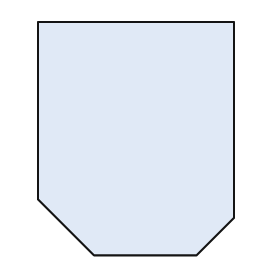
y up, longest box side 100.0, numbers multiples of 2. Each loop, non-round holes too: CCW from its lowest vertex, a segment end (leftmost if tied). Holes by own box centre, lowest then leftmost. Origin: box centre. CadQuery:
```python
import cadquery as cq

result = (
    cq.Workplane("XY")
    .moveTo(-18.0, -50.0)
    .lineTo(26.0, -50.0)
    .lineTo(42.0, -34.0)
    .lineTo(42.0, 50.0)
    .lineTo(-42.0, 50.0)
    .lineTo(-42.0, -26.0)
    .close()
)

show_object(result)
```